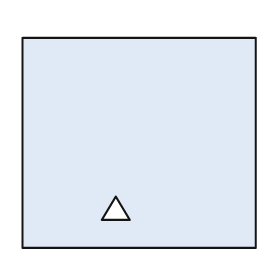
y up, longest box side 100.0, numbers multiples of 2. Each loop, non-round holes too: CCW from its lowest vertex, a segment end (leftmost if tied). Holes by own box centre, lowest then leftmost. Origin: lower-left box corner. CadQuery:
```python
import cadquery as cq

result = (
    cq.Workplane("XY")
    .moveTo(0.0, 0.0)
    .lineTo(100.0, 0.0)
    .lineTo(100.0, 90.0)
    .lineTo(0.0, 90.0)
    .close()
    .moveTo(34.0, 12.0)
    .lineTo(46.0, 12.0)
    .lineTo(40.0, 22.0)
    .close()
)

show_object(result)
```